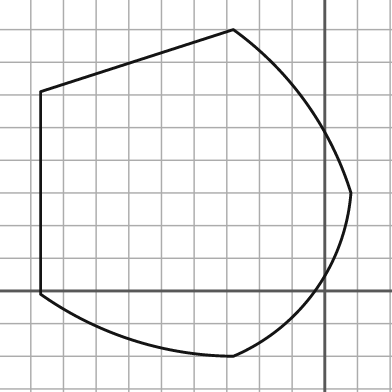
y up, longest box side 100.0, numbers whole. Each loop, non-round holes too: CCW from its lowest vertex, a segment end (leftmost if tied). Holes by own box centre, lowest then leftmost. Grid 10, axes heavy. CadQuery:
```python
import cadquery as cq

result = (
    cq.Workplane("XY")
    .moveTo(-28.0, -20.0)
    .threePointArc((-3.0, 0.0), (8.0, 30.0))
    .threePointArc((-6.0, 58.0), (-28.0, 80.0))
    .lineTo(-87.0, 61.0)
    .lineTo(-87.0, -1.0)
    .threePointArc((-59.0, -15.0), (-28.0, -20.0))
    .close()
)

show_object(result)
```